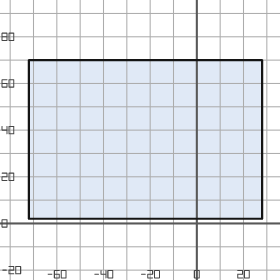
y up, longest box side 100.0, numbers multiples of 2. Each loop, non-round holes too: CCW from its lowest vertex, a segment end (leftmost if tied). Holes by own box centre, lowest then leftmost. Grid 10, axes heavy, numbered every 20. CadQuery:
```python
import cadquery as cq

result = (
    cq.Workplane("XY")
    .moveTo(-72.0, 2.0)
    .lineTo(28.0, 2.0)
    .lineTo(28.0, 70.0)
    .lineTo(-72.0, 70.0)
    .close()
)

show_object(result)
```